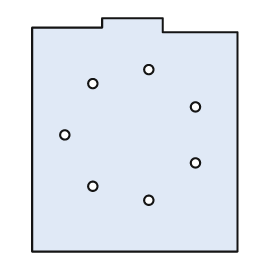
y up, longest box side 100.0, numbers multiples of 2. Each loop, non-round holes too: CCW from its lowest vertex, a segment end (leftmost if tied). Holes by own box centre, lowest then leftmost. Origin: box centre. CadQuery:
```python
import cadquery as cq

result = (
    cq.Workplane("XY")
    .moveTo(-44.0, -50.0)
    .lineTo(44.0, -50.0)
    .lineTo(44.0, 44.0)
    .lineTo(12.0, 44.0)
    .lineTo(12.0, 50.0)
    .lineTo(-14.0, 50.0)
    .lineTo(-14.0, 46.0)
    .lineTo(-44.0, 46.0)
    .close()
    .moveTo(6.0, -28.0)
    .circle(2.0)
    .moveTo(-18.0, -22.0)
    .circle(2.0)
    .moveTo(26.0, -12.0)
    .circle(2.0)
    .moveTo(-30.0, 0.0)
    .circle(2.0)
    .moveTo(26.0, 12.0)
    .circle(2.0)
    .moveTo(-18.0, 22.0)
    .circle(2.0)
    .moveTo(6.0, 28.0)
    .circle(2.0)
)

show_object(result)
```